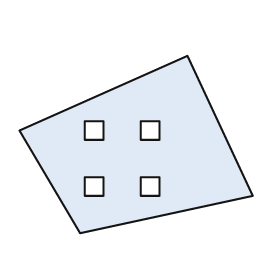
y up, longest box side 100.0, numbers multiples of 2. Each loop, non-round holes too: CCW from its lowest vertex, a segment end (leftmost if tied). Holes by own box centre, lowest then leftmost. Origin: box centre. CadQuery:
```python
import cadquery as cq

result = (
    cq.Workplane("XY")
    .moveTo(-24.0, -38.0)
    .lineTo(50.0, -22.0)
    .lineTo(22.0, 38.0)
    .lineTo(-50.0, 6.0)
    .close()
    .moveTo(-22.0, -22.0)
    .lineTo(-14.0, -22.0)
    .lineTo(-14.0, -14.0)
    .lineTo(-22.0, -14.0)
    .close()
    .moveTo(2.0, -22.0)
    .lineTo(10.0, -22.0)
    .lineTo(10.0, -14.0)
    .lineTo(2.0, -14.0)
    .close()
    .moveTo(-22.0, 2.0)
    .lineTo(-14.0, 2.0)
    .lineTo(-14.0, 10.0)
    .lineTo(-22.0, 10.0)
    .close()
    .moveTo(2.0, 2.0)
    .lineTo(10.0, 2.0)
    .lineTo(10.0, 10.0)
    .lineTo(2.0, 10.0)
    .close()
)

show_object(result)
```